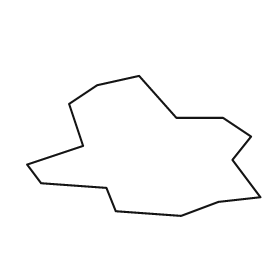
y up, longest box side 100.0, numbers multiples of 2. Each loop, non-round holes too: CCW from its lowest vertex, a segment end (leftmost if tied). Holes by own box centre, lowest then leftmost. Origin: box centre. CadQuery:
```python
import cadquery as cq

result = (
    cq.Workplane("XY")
    .moveTo(16.0, -30.0)
    .lineTo(32.0, -24.0)
    .lineTo(50.0, -22.0)
    .lineTo(38.0, -6.0)
    .lineTo(46.0, 4.0)
    .lineTo(34.0, 12.0)
    .lineTo(14.0, 12.0)
    .lineTo(-2.0, 30.0)
    .lineTo(-20.0, 26.0)
    .lineTo(-32.0, 18.0)
    .lineTo(-26.0, 0.0)
    .lineTo(-50.0, -8.0)
    .lineTo(-44.0, -16.0)
    .lineTo(-16.0, -18.0)
    .lineTo(-12.0, -28.0)
    .close()
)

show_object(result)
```